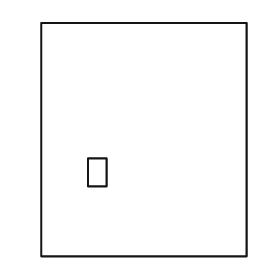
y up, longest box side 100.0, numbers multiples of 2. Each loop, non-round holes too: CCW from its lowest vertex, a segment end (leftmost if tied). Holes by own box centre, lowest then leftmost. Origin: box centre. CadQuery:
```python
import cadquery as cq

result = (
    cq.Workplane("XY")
    .moveTo(-44.0, -50.0)
    .lineTo(44.0, -50.0)
    .lineTo(44.0, 50.0)
    .lineTo(-44.0, 50.0)
    .close()
    .moveTo(-24.0, -20.0)
    .lineTo(-16.0, -20.0)
    .lineTo(-16.0, -8.0)
    .lineTo(-24.0, -8.0)
    .close()
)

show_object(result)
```